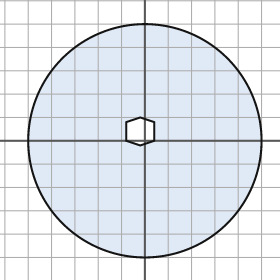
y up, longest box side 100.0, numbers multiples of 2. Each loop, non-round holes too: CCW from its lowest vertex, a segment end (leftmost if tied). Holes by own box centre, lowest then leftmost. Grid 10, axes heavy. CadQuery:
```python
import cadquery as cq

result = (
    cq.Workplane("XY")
    .moveTo(0.0, 0.0)
    .circle(50.0)
    .moveTo(-2.0, -2.0)
    .lineTo(4.0, 0.0)
    .lineTo(4.0, 8.0)
    .lineTo(-2.0, 10.0)
    .lineTo(-8.0, 8.0)
    .lineTo(-8.0, 0.0)
    .close()
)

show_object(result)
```